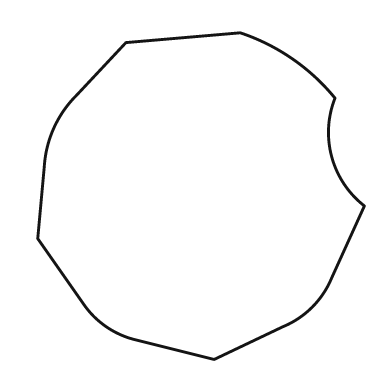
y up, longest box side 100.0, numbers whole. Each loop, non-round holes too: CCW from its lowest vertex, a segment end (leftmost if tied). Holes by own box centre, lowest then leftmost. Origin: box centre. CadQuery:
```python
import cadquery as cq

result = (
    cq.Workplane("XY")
    .moveTo(4.0, -50.0)
    .lineTo(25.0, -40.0)
    .threePointArc((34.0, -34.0), (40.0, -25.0))
    .lineTo(50.0, -3.0)
    .threePointArc((40.0, 12.0), (41.0, 30.0))
    .threePointArc((28.0, 42.0), (12.0, 50.0))
    .lineTo(-23.0, 47.0)
    .lineTo(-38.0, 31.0)
    .threePointArc((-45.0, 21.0), (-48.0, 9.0))
    .lineTo(-50.0, -13.0)
    .lineTo(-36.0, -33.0)
    .threePointArc((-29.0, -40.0), (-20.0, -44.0))
    .close()
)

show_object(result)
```